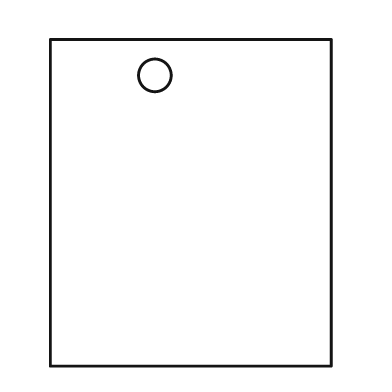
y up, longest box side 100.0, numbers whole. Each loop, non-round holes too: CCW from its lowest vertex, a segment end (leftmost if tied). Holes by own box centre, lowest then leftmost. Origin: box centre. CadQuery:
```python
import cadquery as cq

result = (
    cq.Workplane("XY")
    .moveTo(-43.0, -50.0)
    .lineTo(43.0, -50.0)
    .lineTo(43.0, 50.0)
    .lineTo(-43.0, 50.0)
    .close()
    .moveTo(-11.0, 39.0)
    .circle(5.0)
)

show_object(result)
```